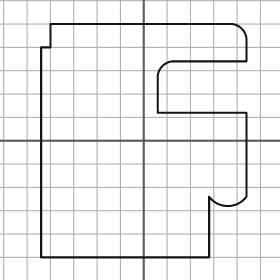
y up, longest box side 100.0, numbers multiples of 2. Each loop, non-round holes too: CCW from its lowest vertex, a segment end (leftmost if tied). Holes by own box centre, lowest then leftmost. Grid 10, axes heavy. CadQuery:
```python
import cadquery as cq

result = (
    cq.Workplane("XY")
    .moveTo(-44.0, -50.0)
    .lineTo(28.0, -50.0)
    .lineTo(28.0, -24.0)
    .threePointArc((36.0, -28.0), (44.0, -24.0))
    .lineTo(44.0, 12.0)
    .lineTo(6.0, 12.0)
    .lineTo(6.0, 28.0)
    .threePointArc((8.0, 32.0), (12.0, 34.0))
    .lineTo(44.0, 34.0)
    .lineTo(44.0, 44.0)
    .threePointArc((42.0, 48.0), (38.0, 50.0))
    .lineTo(-40.0, 50.0)
    .lineTo(-40.0, 40.0)
    .lineTo(-44.0, 40.0)
    .close()
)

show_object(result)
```